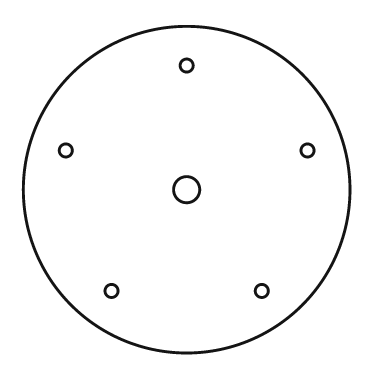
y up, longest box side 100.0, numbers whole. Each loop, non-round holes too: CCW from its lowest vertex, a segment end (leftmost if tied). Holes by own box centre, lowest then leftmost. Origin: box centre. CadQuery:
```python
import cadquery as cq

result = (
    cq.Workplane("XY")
    .moveTo(0.0, 0.0)
    .circle(50.0)
    .moveTo(-23.0, -31.0)
    .circle(2.0)
    .moveTo(23.0, -31.0)
    .circle(2.0)
    .moveTo(0.0, 0.0)
    .circle(4.0)
    .moveTo(-37.0, 12.0)
    .circle(2.0)
    .moveTo(37.0, 12.0)
    .circle(2.0)
    .moveTo(0.0, 38.0)
    .circle(2.0)
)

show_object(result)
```